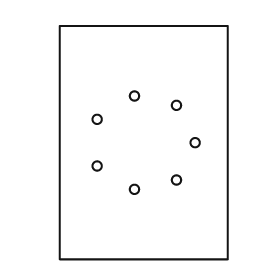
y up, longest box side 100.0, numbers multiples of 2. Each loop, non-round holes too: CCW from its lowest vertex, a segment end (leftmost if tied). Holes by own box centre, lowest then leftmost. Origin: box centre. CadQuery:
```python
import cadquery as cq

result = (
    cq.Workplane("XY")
    .moveTo(-36.0, -50.0)
    .lineTo(36.0, -50.0)
    .lineTo(36.0, 50.0)
    .lineTo(-36.0, 50.0)
    .close()
    .moveTo(-4.0, -20.0)
    .circle(2.0)
    .moveTo(14.0, -16.0)
    .circle(2.0)
    .moveTo(-20.0, -10.0)
    .circle(2.0)
    .moveTo(22.0, 0.0)
    .circle(2.0)
    .moveTo(-20.0, 10.0)
    .circle(2.0)
    .moveTo(14.0, 16.0)
    .circle(2.0)
    .moveTo(-4.0, 20.0)
    .circle(2.0)
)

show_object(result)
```